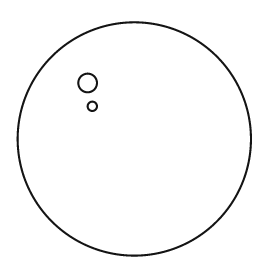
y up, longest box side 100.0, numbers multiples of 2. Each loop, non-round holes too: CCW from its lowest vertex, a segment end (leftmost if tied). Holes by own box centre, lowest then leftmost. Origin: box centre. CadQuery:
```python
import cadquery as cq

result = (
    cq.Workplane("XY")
    .moveTo(0.0, 0.0)
    .circle(50.0)
    .moveTo(-18.0, 14.0)
    .circle(2.0)
    .moveTo(-20.0, 24.0)
    .circle(4.0)
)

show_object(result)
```